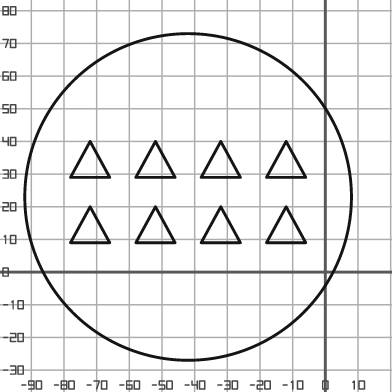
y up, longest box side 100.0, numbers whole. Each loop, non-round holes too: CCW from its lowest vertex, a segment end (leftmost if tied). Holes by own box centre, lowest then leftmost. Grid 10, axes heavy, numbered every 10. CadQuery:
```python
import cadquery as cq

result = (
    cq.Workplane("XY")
    .moveTo(-42.0, 23.0)
    .circle(50.0)
    .moveTo(-78.0, 9.0)
    .lineTo(-66.0, 9.0)
    .lineTo(-72.0, 20.0)
    .close()
    .moveTo(-58.0, 9.0)
    .lineTo(-46.0, 9.0)
    .lineTo(-52.0, 20.0)
    .close()
    .moveTo(-38.0, 9.0)
    .lineTo(-26.0, 9.0)
    .lineTo(-32.0, 20.0)
    .close()
    .moveTo(-18.0, 9.0)
    .lineTo(-6.0, 9.0)
    .lineTo(-12.0, 20.0)
    .close()
    .moveTo(-78.0, 29.0)
    .lineTo(-66.0, 29.0)
    .lineTo(-72.0, 40.0)
    .close()
    .moveTo(-58.0, 29.0)
    .lineTo(-46.0, 29.0)
    .lineTo(-52.0, 40.0)
    .close()
    .moveTo(-38.0, 29.0)
    .lineTo(-26.0, 29.0)
    .lineTo(-32.0, 40.0)
    .close()
    .moveTo(-18.0, 29.0)
    .lineTo(-6.0, 29.0)
    .lineTo(-12.0, 40.0)
    .close()
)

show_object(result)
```